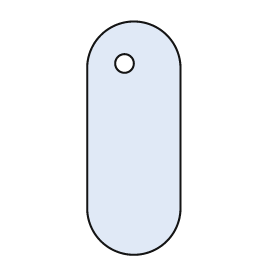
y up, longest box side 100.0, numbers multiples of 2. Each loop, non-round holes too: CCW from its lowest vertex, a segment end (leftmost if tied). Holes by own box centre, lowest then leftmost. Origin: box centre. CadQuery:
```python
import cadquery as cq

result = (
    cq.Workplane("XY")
    .moveTo(-20.0, -30.0)
    .threePointArc((0.0, -50.0), (20.0, -30.0))
    .lineTo(20.0, 30.0)
    .threePointArc((0.0, 50.0), (-20.0, 30.0))
    .close()
    .moveTo(-4.0, 32.0)
    .circle(4.0)
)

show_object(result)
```